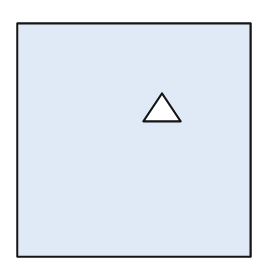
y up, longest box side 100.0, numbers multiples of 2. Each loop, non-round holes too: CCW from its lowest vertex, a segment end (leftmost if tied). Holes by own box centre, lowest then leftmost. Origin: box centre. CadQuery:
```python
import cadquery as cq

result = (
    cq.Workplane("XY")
    .moveTo(-50.0, -50.0)
    .lineTo(50.0, -50.0)
    .lineTo(50.0, 50.0)
    .lineTo(-50.0, 50.0)
    .close()
    .moveTo(4.0, 8.0)
    .lineTo(20.0, 8.0)
    .lineTo(12.0, 20.0)
    .close()
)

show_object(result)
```